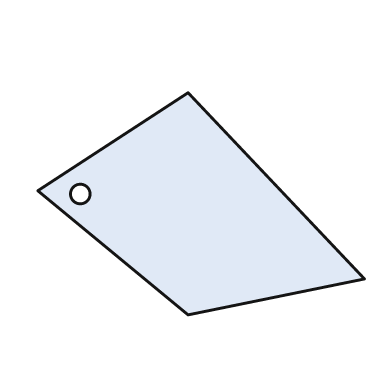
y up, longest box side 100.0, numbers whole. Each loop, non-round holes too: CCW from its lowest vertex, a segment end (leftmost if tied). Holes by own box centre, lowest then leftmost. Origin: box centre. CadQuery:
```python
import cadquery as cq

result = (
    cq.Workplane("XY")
    .moveTo(-4.0, -34.0)
    .lineTo(50.0, -23.0)
    .lineTo(-4.0, 34.0)
    .lineTo(-50.0, 4.0)
    .close()
    .moveTo(-37.0, 3.0)
    .circle(3.0)
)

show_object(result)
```